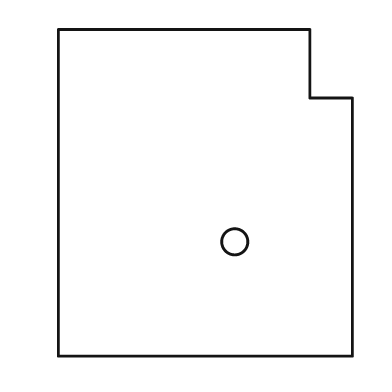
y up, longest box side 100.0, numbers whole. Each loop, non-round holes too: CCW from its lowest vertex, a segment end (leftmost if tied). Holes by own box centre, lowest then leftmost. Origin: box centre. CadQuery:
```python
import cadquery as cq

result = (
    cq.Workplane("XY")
    .moveTo(-45.0, -50.0)
    .lineTo(45.0, -50.0)
    .lineTo(45.0, 29.0)
    .lineTo(32.0, 29.0)
    .lineTo(32.0, 50.0)
    .lineTo(-45.0, 50.0)
    .close()
    .moveTo(9.0, -15.0)
    .circle(4.0)
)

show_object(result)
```